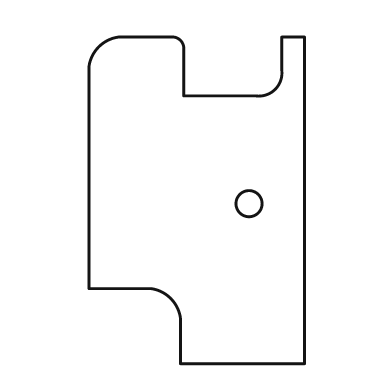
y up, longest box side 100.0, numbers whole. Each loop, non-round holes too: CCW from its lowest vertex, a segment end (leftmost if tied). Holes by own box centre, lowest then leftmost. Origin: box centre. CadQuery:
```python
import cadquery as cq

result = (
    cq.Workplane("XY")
    .moveTo(-5.0, -50.0)
    .lineTo(33.0, -50.0)
    .lineTo(33.0, 50.0)
    .lineTo(26.0, 50.0)
    .lineTo(26.0, 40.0)
    .threePointArc((24.0, 34.0), (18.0, 32.0))
    .lineTo(-4.0, 32.0)
    .lineTo(-4.0, 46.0)
    .threePointArc((-5.0, 49.0), (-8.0, 50.0))
    .lineTo(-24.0, 50.0)
    .threePointArc((-30.0, 47.0), (-33.0, 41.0))
    .lineTo(-33.0, -27.0)
    .lineTo(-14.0, -27.0)
    .threePointArc((-8.0, -30.0), (-5.0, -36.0))
    .close()
    .moveTo(16.0, -1.0)
    .circle(4.0)
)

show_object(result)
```